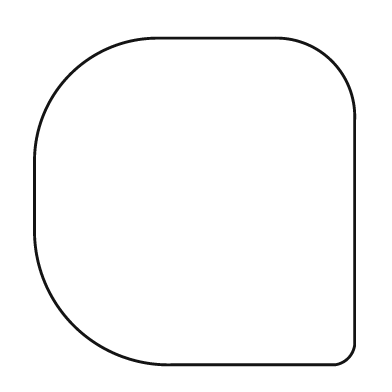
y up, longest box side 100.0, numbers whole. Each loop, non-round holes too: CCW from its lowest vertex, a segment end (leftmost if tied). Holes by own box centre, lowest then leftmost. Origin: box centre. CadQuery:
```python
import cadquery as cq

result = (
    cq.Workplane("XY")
    .moveTo(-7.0, -50.0)
    .lineTo(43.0, -50.0)
    .threePointArc((47.0, -48.0), (49.0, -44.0))
    .lineTo(49.0, 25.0)
    .threePointArc((42.0, 43.0), (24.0, 50.0))
    .lineTo(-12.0, 50.0)
    .threePointArc((-38.0, 39.0), (-49.0, 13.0))
    .lineTo(-49.0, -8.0)
    .threePointArc((-37.0, -38.0), (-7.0, -50.0))
    .close()
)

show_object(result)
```